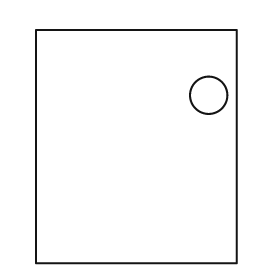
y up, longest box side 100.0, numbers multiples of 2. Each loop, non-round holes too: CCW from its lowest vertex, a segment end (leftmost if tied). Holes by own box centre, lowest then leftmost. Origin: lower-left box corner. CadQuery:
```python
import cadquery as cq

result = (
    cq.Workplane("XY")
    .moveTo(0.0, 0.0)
    .lineTo(86.0, 0.0)
    .lineTo(86.0, 100.0)
    .lineTo(0.0, 100.0)
    .close()
    .moveTo(74.0, 72.0)
    .circle(8.0)
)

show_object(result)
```